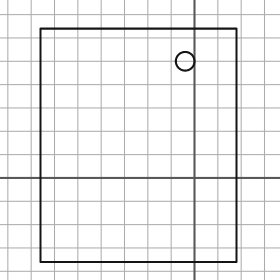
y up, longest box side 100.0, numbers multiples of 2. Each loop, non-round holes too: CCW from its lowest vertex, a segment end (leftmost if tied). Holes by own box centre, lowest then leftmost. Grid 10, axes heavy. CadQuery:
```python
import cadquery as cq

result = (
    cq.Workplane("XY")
    .moveTo(-66.0, -36.0)
    .lineTo(18.0, -36.0)
    .lineTo(18.0, 64.0)
    .lineTo(-66.0, 64.0)
    .close()
    .moveTo(-4.0, 50.0)
    .circle(4.0)
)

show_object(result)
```